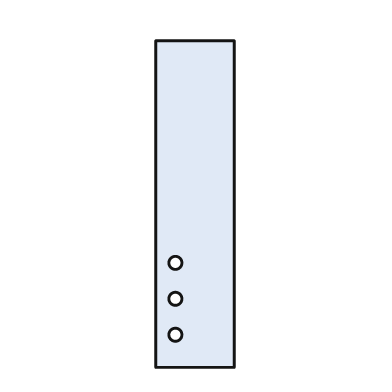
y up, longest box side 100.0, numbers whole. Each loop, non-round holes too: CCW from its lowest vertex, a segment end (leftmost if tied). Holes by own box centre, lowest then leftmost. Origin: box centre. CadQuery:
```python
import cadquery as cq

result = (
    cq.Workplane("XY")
    .moveTo(-12.0, -50.0)
    .lineTo(12.0, -50.0)
    .lineTo(12.0, 50.0)
    .lineTo(-12.0, 50.0)
    .close()
    .moveTo(-6.0, -40.0)
    .circle(2.0)
    .moveTo(-6.0, -29.0)
    .circle(2.0)
    .moveTo(-6.0, -18.0)
    .circle(2.0)
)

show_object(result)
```